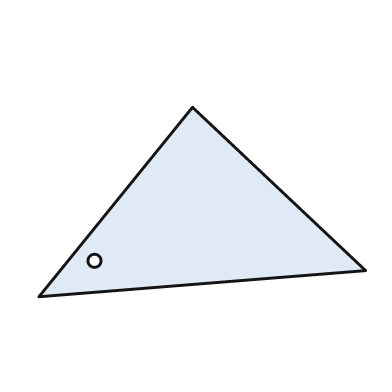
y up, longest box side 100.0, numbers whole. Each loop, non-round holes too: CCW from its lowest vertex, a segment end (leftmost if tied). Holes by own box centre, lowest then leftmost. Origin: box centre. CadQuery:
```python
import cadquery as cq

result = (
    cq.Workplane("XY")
    .moveTo(-50.0, -29.0)
    .lineTo(50.0, -21.0)
    .lineTo(-3.0, 29.0)
    .close()
    .moveTo(-33.0, -18.0)
    .circle(2.0)
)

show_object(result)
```